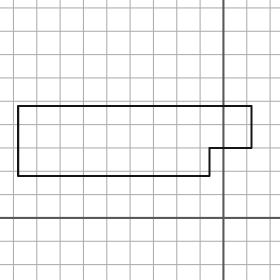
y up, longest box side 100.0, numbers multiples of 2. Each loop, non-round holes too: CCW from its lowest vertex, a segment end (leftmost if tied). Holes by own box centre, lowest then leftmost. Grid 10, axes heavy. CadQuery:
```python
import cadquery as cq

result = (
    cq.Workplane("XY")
    .moveTo(-88.0, 18.0)
    .lineTo(-6.0, 18.0)
    .lineTo(-6.0, 30.0)
    .lineTo(12.0, 30.0)
    .lineTo(12.0, 48.0)
    .lineTo(-88.0, 48.0)
    .close()
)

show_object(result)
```